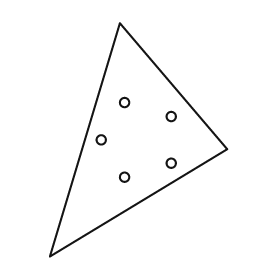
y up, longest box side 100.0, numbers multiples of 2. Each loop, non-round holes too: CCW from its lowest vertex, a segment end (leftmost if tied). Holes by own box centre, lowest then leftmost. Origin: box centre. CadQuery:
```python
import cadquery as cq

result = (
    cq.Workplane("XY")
    .moveTo(-38.0, -50.0)
    .lineTo(38.0, -4.0)
    .lineTo(-8.0, 50.0)
    .close()
    .moveTo(-6.0, -16.0)
    .circle(2.0)
    .moveTo(14.0, -10.0)
    .circle(2.0)
    .moveTo(-16.0, 0.0)
    .circle(2.0)
    .moveTo(14.0, 10.0)
    .circle(2.0)
    .moveTo(-6.0, 16.0)
    .circle(2.0)
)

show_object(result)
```